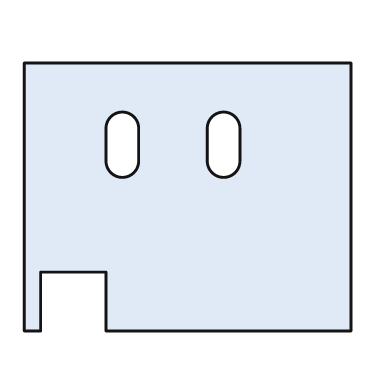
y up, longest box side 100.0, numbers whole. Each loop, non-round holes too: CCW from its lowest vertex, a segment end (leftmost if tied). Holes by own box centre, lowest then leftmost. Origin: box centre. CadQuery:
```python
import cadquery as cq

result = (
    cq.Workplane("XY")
    .moveTo(-50.0, -41.0)
    .lineTo(-45.0, -41.0)
    .lineTo(-45.0, -23.0)
    .lineTo(-25.0, -23.0)
    .lineTo(-25.0, -41.0)
    .lineTo(50.0, -41.0)
    .lineTo(50.0, 41.0)
    .lineTo(-50.0, 41.0)
    .close()
    .moveTo(-25.0, 11.0)
    .threePointArc((-20.0, 6.0), (-15.0, 11.0))
    .lineTo(-15.0, 21.0)
    .threePointArc((-20.0, 26.0), (-25.0, 21.0))
    .close()
    .moveTo(6.0, 11.0)
    .threePointArc((11.0, 6.0), (16.0, 11.0))
    .lineTo(16.0, 21.0)
    .threePointArc((11.0, 26.0), (6.0, 21.0))
    .close()
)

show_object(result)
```